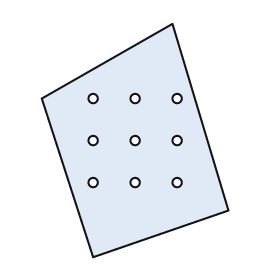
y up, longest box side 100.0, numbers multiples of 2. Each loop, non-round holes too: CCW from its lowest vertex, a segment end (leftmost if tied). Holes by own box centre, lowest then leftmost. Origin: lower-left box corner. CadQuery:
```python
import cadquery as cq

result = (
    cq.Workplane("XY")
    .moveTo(22.0, 0.0)
    .lineTo(80.0, 20.0)
    .lineTo(56.0, 100.0)
    .lineTo(0.0, 68.0)
    .close()
    .moveTo(22.0, 32.0)
    .circle(2.0)
    .moveTo(40.0, 32.0)
    .circle(2.0)
    .moveTo(58.0, 32.0)
    .circle(2.0)
    .moveTo(22.0, 50.0)
    .circle(2.0)
    .moveTo(40.0, 50.0)
    .circle(2.0)
    .moveTo(58.0, 50.0)
    .circle(2.0)
    .moveTo(22.0, 68.0)
    .circle(2.0)
    .moveTo(40.0, 68.0)
    .circle(2.0)
    .moveTo(58.0, 68.0)
    .circle(2.0)
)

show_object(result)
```